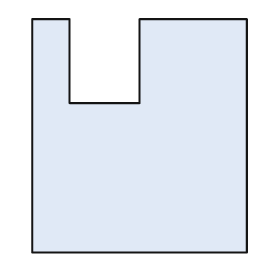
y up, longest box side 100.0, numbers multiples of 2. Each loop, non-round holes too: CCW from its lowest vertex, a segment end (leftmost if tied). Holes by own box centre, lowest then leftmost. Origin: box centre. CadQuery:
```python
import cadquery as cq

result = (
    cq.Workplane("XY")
    .moveTo(-46.0, -50.0)
    .lineTo(46.0, -50.0)
    .lineTo(46.0, 50.0)
    .lineTo(0.0, 50.0)
    .lineTo(0.0, 14.0)
    .lineTo(-30.0, 14.0)
    .lineTo(-30.0, 50.0)
    .lineTo(-46.0, 50.0)
    .close()
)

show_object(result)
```